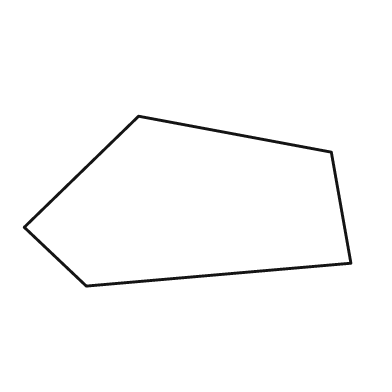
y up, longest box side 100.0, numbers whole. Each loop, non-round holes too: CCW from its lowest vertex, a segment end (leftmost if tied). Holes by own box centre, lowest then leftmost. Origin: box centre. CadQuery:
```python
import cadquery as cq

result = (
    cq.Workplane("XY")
    .moveTo(-31.0, -26.0)
    .lineTo(50.0, -19.0)
    .lineTo(44.0, 15.0)
    .lineTo(-15.0, 26.0)
    .lineTo(-50.0, -8.0)
    .close()
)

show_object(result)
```